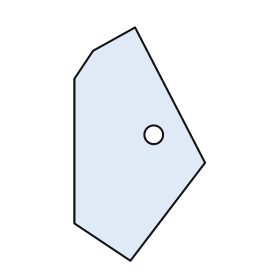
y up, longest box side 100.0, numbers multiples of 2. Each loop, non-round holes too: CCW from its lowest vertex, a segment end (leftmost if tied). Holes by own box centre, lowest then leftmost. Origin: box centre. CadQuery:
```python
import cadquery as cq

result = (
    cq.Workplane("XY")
    .moveTo(-4.0, -50.0)
    .lineTo(28.0, -8.0)
    .lineTo(-2.0, 50.0)
    .lineTo(-20.0, 40.0)
    .lineTo(-28.0, 28.0)
    .lineTo(-28.0, -34.0)
    .close()
    .moveTo(6.0, 4.0)
    .circle(4.0)
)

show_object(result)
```